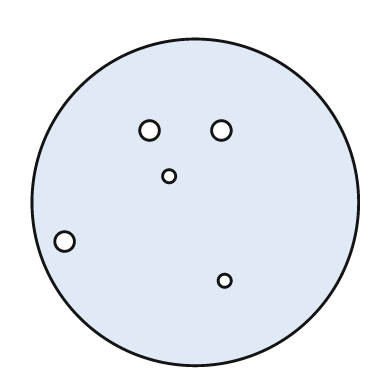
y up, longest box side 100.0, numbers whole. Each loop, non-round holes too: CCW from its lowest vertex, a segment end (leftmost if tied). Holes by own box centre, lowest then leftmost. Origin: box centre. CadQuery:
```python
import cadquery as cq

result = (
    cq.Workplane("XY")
    .moveTo(0.0, 0.0)
    .circle(50.0)
    .moveTo(9.0, -24.0)
    .circle(2.0)
    .moveTo(-40.0, -12.0)
    .circle(3.0)
    .moveTo(-8.0, 8.0)
    .circle(2.0)
    .moveTo(-14.0, 22.0)
    .circle(3.0)
    .moveTo(8.0, 22.0)
    .circle(3.0)
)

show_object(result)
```